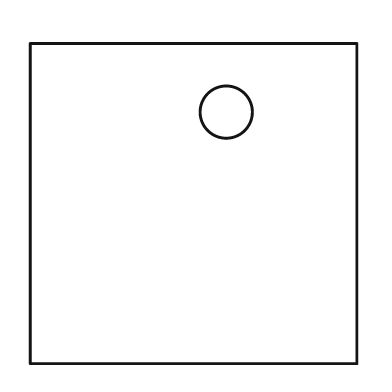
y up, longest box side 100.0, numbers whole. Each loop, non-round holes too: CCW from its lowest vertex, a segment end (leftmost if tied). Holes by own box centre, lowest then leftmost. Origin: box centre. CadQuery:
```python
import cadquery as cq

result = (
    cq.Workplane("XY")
    .moveTo(-50.0, -49.0)
    .lineTo(50.0, -49.0)
    .lineTo(50.0, 49.0)
    .lineTo(-50.0, 49.0)
    .close()
    .moveTo(10.0, 28.0)
    .circle(8.0)
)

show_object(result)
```